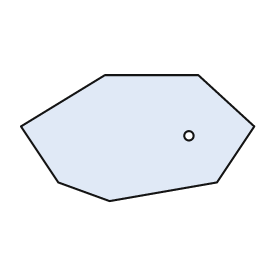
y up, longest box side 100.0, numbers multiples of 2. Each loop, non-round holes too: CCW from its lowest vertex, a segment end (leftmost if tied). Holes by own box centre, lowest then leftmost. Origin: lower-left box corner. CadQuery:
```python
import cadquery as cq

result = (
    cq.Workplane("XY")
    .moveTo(38.0, 0.0)
    .lineTo(84.0, 8.0)
    .lineTo(100.0, 32.0)
    .lineTo(76.0, 54.0)
    .lineTo(36.0, 54.0)
    .lineTo(0.0, 32.0)
    .lineTo(16.0, 8.0)
    .close()
    .moveTo(72.0, 28.0)
    .circle(2.0)
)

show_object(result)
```